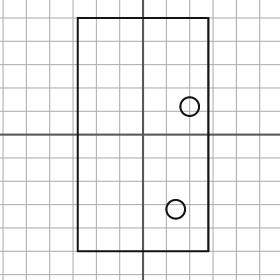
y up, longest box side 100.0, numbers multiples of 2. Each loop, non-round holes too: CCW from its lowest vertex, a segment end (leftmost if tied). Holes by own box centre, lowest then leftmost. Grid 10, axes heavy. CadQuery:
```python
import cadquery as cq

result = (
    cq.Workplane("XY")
    .moveTo(-28.0, -50.0)
    .lineTo(28.0, -50.0)
    .lineTo(28.0, 50.0)
    .lineTo(-28.0, 50.0)
    .close()
    .moveTo(14.0, -32.0)
    .circle(4.0)
    .moveTo(20.0, 12.0)
    .circle(4.0)
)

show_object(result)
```